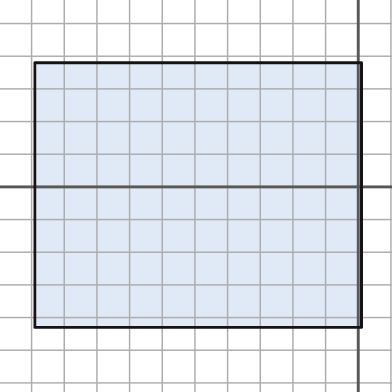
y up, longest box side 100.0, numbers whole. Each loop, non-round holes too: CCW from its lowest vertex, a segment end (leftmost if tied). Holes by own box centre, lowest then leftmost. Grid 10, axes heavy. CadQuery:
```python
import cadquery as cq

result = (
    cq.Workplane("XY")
    .moveTo(-99.0, -43.0)
    .lineTo(1.0, -43.0)
    .lineTo(1.0, 38.0)
    .lineTo(-99.0, 38.0)
    .close()
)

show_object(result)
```